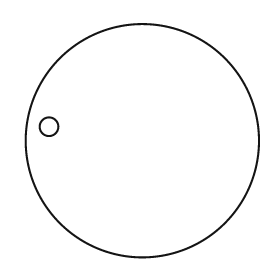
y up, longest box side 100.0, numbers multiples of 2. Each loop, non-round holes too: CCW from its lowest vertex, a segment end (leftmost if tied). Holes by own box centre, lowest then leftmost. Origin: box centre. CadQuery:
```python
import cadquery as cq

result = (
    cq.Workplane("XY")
    .moveTo(0.0, 0.0)
    .circle(50.0)
    .moveTo(-40.0, 6.0)
    .circle(4.0)
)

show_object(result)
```